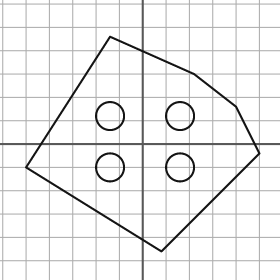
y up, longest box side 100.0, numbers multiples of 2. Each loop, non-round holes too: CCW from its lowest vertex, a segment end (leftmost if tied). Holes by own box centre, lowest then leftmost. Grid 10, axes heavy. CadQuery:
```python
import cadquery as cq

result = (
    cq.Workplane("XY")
    .moveTo(8.0, -46.0)
    .lineTo(50.0, -4.0)
    .lineTo(40.0, 16.0)
    .lineTo(22.0, 30.0)
    .lineTo(-14.0, 46.0)
    .lineTo(-50.0, -10.0)
    .close()
    .moveTo(-14.0, -10.0)
    .circle(6.0)
    .moveTo(16.0, -10.0)
    .circle(6.0)
    .moveTo(-14.0, 12.0)
    .circle(6.0)
    .moveTo(16.0, 12.0)
    .circle(6.0)
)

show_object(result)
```